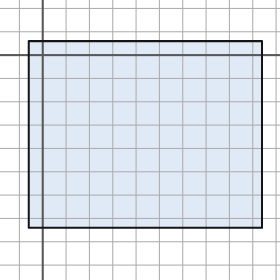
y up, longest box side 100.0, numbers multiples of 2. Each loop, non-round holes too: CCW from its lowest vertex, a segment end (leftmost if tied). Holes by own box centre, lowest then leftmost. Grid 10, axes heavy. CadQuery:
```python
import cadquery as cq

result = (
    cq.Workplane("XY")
    .moveTo(-6.0, -74.0)
    .lineTo(94.0, -74.0)
    .lineTo(94.0, 6.0)
    .lineTo(-6.0, 6.0)
    .close()
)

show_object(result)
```